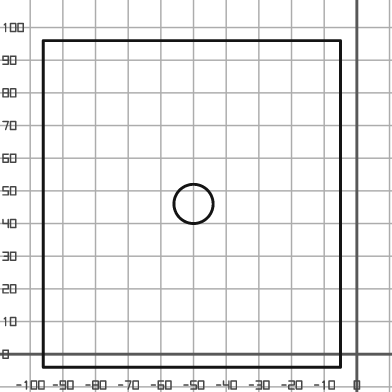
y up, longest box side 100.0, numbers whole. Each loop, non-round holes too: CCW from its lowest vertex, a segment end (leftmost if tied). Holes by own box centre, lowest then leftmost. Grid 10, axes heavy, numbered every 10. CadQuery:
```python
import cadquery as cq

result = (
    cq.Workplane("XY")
    .moveTo(-96.0, -4.0)
    .lineTo(-5.0, -4.0)
    .lineTo(-5.0, 96.0)
    .lineTo(-96.0, 96.0)
    .close()
    .moveTo(-50.0, 46.0)
    .circle(6.0)
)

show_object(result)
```